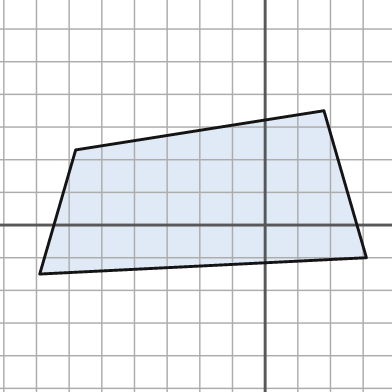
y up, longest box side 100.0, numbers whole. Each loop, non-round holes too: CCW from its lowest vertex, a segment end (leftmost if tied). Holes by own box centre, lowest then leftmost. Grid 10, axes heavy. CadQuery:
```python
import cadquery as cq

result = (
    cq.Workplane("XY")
    .moveTo(-69.0, -15.0)
    .lineTo(31.0, -10.0)
    .lineTo(18.0, 35.0)
    .lineTo(-58.0, 23.0)
    .close()
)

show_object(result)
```